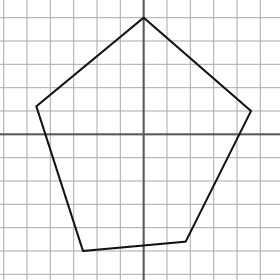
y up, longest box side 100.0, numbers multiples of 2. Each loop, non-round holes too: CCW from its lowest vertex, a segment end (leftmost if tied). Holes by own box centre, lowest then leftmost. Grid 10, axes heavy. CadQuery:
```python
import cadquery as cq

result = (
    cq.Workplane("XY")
    .moveTo(-26.0, -50.0)
    .lineTo(18.0, -46.0)
    .lineTo(46.0, 10.0)
    .lineTo(0.0, 50.0)
    .lineTo(-46.0, 12.0)
    .close()
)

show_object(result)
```